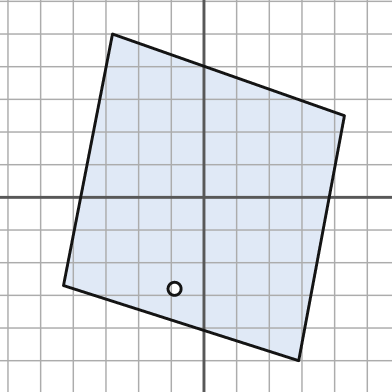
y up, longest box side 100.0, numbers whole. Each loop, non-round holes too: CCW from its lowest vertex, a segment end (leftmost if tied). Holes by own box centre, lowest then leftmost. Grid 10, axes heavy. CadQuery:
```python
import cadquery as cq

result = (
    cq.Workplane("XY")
    .moveTo(29.0, -50.0)
    .lineTo(43.0, 25.0)
    .lineTo(-28.0, 50.0)
    .lineTo(-43.0, -27.0)
    .close()
    .moveTo(-9.0, -28.0)
    .circle(2.0)
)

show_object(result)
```